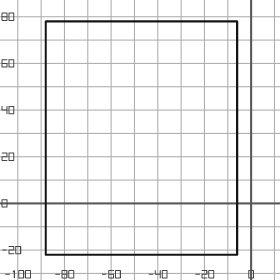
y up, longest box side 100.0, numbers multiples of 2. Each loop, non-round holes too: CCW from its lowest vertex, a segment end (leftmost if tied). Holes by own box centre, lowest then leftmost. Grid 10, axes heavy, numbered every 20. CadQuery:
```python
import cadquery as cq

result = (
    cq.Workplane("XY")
    .moveTo(-88.0, -22.0)
    .lineTo(-6.0, -22.0)
    .lineTo(-6.0, 78.0)
    .lineTo(-88.0, 78.0)
    .close()
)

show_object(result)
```